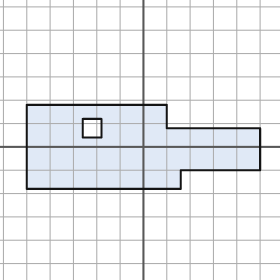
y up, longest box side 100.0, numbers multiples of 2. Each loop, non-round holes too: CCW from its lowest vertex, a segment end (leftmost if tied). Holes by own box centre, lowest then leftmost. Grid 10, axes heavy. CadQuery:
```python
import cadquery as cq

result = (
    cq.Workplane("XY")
    .moveTo(-50.0, -18.0)
    .lineTo(16.0, -18.0)
    .lineTo(16.0, -10.0)
    .lineTo(50.0, -10.0)
    .lineTo(50.0, 8.0)
    .lineTo(10.0, 8.0)
    .lineTo(10.0, 18.0)
    .lineTo(-50.0, 18.0)
    .close()
    .moveTo(-26.0, 4.0)
    .lineTo(-18.0, 4.0)
    .lineTo(-18.0, 12.0)
    .lineTo(-26.0, 12.0)
    .close()
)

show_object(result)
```